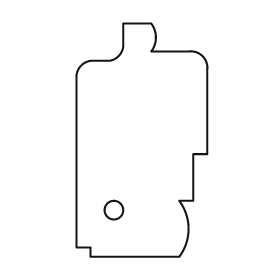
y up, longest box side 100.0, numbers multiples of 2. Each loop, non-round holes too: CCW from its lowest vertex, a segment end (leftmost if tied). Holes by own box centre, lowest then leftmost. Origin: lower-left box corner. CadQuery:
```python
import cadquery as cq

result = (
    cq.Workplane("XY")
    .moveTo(6.0, 0.0)
    .lineTo(44.0, 0.0)
    .threePointArc((48.0, 12.0), (44.0, 24.0))
    .lineTo(50.0, 24.0)
    .lineTo(50.0, 44.0)
    .lineTo(56.0, 44.0)
    .lineTo(56.0, 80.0)
    .threePointArc((54.0, 86.0), (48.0, 88.0))
    .lineTo(32.0, 88.0)
    .threePointArc((34.0, 94.0), (32.0, 100.0))
    .lineTo(20.0, 100.0)
    .lineTo(20.0, 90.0)
    .threePointArc((18.0, 86.0), (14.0, 84.0))
    .lineTo(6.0, 84.0)
    .threePointArc((2.0, 82.0), (0.0, 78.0))
    .lineTo(0.0, 4.0)
    .lineTo(6.0, 4.0)
    .close()
    .moveTo(16.0, 20.0)
    .circle(4.0)
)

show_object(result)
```